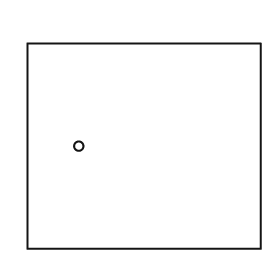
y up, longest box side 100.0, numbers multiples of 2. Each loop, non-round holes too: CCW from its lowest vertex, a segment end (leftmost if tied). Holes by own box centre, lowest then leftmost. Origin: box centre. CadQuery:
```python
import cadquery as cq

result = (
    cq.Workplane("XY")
    .moveTo(-50.0, -44.0)
    .lineTo(50.0, -44.0)
    .lineTo(50.0, 44.0)
    .lineTo(-50.0, 44.0)
    .close()
    .moveTo(-28.0, 0.0)
    .circle(2.0)
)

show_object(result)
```